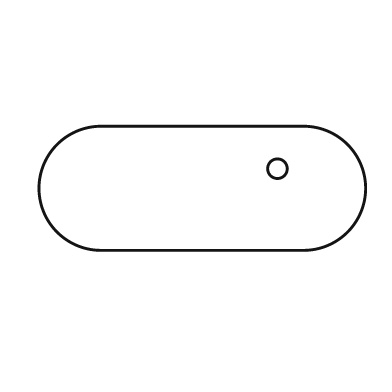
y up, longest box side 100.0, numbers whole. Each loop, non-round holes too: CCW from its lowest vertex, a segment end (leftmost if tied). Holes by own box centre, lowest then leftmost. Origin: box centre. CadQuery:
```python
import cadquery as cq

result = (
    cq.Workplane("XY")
    .moveTo(-31.0, -19.0)
    .lineTo(31.0, -19.0)
    .threePointArc((50.0, 0.0), (31.0, 19.0))
    .lineTo(-31.0, 19.0)
    .threePointArc((-50.0, 0.0), (-31.0, -19.0))
    .close()
    .moveTo(23.0, 6.0)
    .circle(3.0)
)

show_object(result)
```